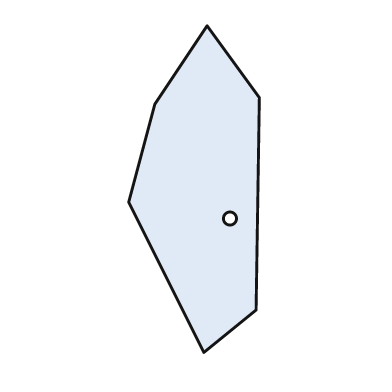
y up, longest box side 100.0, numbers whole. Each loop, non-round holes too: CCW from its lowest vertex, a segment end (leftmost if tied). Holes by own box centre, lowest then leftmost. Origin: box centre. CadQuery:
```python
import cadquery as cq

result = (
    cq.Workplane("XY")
    .moveTo(3.0, -50.0)
    .lineTo(19.0, -37.0)
    .lineTo(20.0, 28.0)
    .lineTo(4.0, 50.0)
    .lineTo(-12.0, 26.0)
    .lineTo(-20.0, -4.0)
    .close()
    .moveTo(11.0, -9.0)
    .circle(2.0)
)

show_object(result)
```